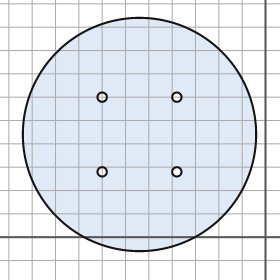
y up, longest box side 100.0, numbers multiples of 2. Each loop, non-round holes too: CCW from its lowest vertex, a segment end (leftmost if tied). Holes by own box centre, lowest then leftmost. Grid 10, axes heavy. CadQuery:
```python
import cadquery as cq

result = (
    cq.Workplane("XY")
    .moveTo(-54.0, 44.0)
    .circle(50.0)
    .moveTo(-70.0, 28.0)
    .circle(2.0)
    .moveTo(-38.0, 28.0)
    .circle(2.0)
    .moveTo(-70.0, 60.0)
    .circle(2.0)
    .moveTo(-38.0, 60.0)
    .circle(2.0)
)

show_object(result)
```